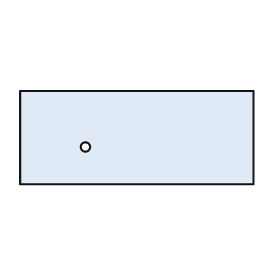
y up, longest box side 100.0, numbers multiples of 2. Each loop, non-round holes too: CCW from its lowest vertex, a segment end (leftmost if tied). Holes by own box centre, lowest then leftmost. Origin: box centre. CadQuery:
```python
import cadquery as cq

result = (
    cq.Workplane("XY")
    .moveTo(-50.0, -20.0)
    .lineTo(50.0, -20.0)
    .lineTo(50.0, 20.0)
    .lineTo(-50.0, 20.0)
    .close()
    .moveTo(-22.0, -4.0)
    .circle(2.0)
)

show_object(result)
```